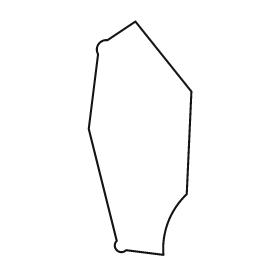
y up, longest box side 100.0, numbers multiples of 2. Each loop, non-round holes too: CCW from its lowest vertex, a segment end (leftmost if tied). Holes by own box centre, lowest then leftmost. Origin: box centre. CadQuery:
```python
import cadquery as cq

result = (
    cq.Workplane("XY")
    .moveTo(10.0, -50.0)
    .threePointArc((12.0, -36.0), (20.0, -24.0))
    .lineTo(22.0, 20.0)
    .lineTo(-2.0, 50.0)
    .lineTo(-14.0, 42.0)
    .threePointArc((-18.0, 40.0), (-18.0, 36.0))
    .lineTo(-22.0, 4.0)
    .lineTo(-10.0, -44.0)
    .threePointArc((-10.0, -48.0), (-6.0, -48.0))
    .close()
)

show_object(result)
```